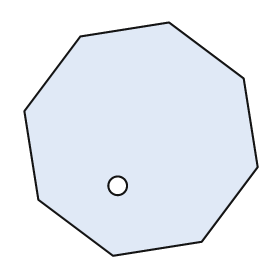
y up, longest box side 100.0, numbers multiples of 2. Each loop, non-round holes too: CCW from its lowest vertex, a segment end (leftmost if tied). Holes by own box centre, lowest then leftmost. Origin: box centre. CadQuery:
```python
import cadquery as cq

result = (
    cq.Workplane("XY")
    .moveTo(-12.0, -50.0)
    .lineTo(26.0, -44.0)
    .lineTo(50.0, -12.0)
    .lineTo(44.0, 26.0)
    .lineTo(12.0, 50.0)
    .lineTo(-26.0, 44.0)
    .lineTo(-50.0, 12.0)
    .lineTo(-44.0, -26.0)
    .close()
    .moveTo(-10.0, -20.0)
    .circle(4.0)
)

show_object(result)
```